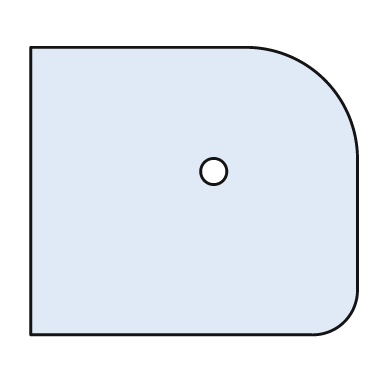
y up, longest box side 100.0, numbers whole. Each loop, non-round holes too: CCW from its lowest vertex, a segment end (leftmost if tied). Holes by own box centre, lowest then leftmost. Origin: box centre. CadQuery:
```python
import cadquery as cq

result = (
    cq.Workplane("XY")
    .moveTo(-50.0, -44.0)
    .lineTo(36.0, -44.0)
    .threePointArc((46.0, -40.0), (50.0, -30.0))
    .lineTo(50.0, 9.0)
    .threePointArc((40.0, 34.0), (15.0, 44.0))
    .lineTo(-50.0, 44.0)
    .close()
    .moveTo(6.0, 6.0)
    .circle(4.0)
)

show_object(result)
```